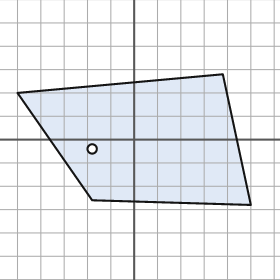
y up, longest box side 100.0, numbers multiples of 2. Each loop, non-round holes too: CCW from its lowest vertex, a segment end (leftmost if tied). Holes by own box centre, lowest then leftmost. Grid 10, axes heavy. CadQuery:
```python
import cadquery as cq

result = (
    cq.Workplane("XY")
    .moveTo(50.0, -28.0)
    .lineTo(38.0, 28.0)
    .lineTo(-50.0, 20.0)
    .lineTo(-18.0, -26.0)
    .close()
    .moveTo(-18.0, -4.0)
    .circle(2.0)
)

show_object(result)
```